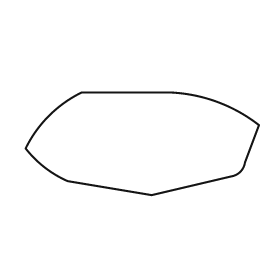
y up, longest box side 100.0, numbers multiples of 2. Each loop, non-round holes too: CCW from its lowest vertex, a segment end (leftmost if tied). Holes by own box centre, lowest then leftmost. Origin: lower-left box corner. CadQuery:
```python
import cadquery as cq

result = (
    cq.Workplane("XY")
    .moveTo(54.0, 0.0)
    .lineTo(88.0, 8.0)
    .threePointArc((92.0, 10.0), (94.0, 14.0))
    .lineTo(100.0, 30.0)
    .threePointArc((82.0, 40.0), (62.0, 44.0))
    .lineTo(24.0, 44.0)
    .threePointArc((10.0, 34.0), (0.0, 20.0))
    .threePointArc((8.0, 12.0), (18.0, 6.0))
    .close()
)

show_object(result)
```